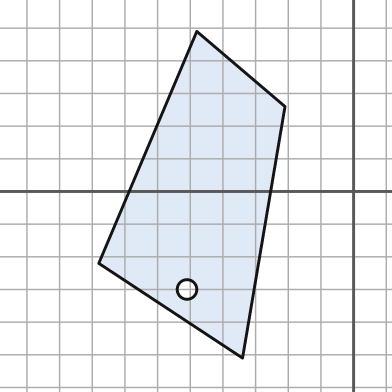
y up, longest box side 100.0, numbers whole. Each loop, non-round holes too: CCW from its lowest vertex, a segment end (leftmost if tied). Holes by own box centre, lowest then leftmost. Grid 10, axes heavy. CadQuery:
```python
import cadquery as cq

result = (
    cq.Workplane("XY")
    .moveTo(-34.0, -51.0)
    .lineTo(-21.0, 26.0)
    .lineTo(-48.0, 49.0)
    .lineTo(-78.0, -22.0)
    .close()
    .moveTo(-51.0, -30.0)
    .circle(3.0)
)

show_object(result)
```